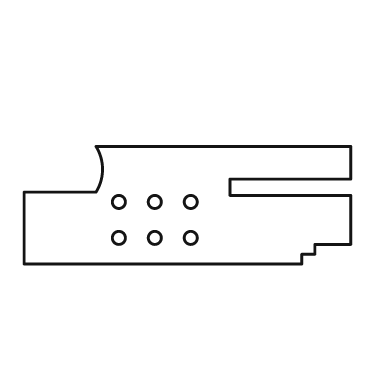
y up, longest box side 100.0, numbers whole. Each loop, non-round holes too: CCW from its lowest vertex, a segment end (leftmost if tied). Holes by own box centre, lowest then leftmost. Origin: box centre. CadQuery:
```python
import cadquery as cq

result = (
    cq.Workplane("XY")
    .moveTo(-50.0, -18.0)
    .lineTo(35.0, -18.0)
    .lineTo(35.0, -15.0)
    .lineTo(39.0, -15.0)
    .lineTo(39.0, -12.0)
    .lineTo(50.0, -12.0)
    .lineTo(50.0, 3.0)
    .lineTo(13.0, 3.0)
    .lineTo(13.0, 8.0)
    .lineTo(50.0, 8.0)
    .lineTo(50.0, 18.0)
    .lineTo(-28.0, 18.0)
    .threePointArc((-26.0, 11.0), (-28.0, 4.0))
    .lineTo(-50.0, 4.0)
    .close()
    .moveTo(-21.0, -10.0)
    .circle(2.0)
    .moveTo(-10.0, -10.0)
    .circle(2.0)
    .moveTo(1.0, -10.0)
    .circle(2.0)
    .moveTo(-21.0, 1.0)
    .circle(2.0)
    .moveTo(-10.0, 1.0)
    .circle(2.0)
    .moveTo(1.0, 1.0)
    .circle(2.0)
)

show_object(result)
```